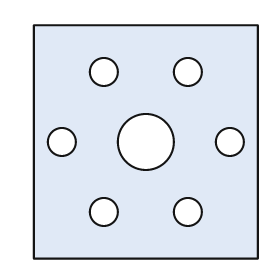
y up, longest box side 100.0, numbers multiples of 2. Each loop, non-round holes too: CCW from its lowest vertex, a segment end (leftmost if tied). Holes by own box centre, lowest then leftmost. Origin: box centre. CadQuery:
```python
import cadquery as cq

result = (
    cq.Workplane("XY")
    .moveTo(-48.0, -50.0)
    .lineTo(48.0, -50.0)
    .lineTo(48.0, 50.0)
    .lineTo(-48.0, 50.0)
    .close()
    .moveTo(-18.0, -30.0)
    .circle(6.0)
    .moveTo(18.0, -30.0)
    .circle(6.0)
    .moveTo(-36.0, 0.0)
    .circle(6.0)
    .moveTo(0.0, 0.0)
    .circle(12.0)
    .moveTo(36.0, 0.0)
    .circle(6.0)
    .moveTo(-18.0, 30.0)
    .circle(6.0)
    .moveTo(18.0, 30.0)
    .circle(6.0)
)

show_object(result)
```